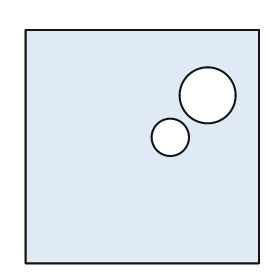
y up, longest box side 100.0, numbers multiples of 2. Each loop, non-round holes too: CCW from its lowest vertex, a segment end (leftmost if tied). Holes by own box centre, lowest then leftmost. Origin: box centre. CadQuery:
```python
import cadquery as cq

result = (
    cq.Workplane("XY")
    .moveTo(-50.0, -50.0)
    .lineTo(50.0, -50.0)
    .lineTo(50.0, 50.0)
    .lineTo(-50.0, 50.0)
    .close()
    .moveTo(12.0, 4.0)
    .circle(8.0)
    .moveTo(28.0, 22.0)
    .circle(12.0)
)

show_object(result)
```